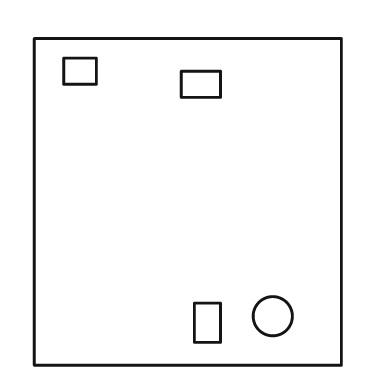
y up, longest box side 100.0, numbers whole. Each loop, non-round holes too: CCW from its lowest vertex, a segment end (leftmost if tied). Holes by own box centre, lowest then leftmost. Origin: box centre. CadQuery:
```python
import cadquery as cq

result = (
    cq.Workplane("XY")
    .moveTo(-47.0, -50.0)
    .lineTo(47.0, -50.0)
    .lineTo(47.0, 50.0)
    .lineTo(-47.0, 50.0)
    .close()
    .moveTo(2.0, -43.0)
    .lineTo(10.0, -43.0)
    .lineTo(10.0, -31.0)
    .lineTo(2.0, -31.0)
    .close()
    .moveTo(26.0, -35.0)
    .circle(6.0)
    .moveTo(-2.0, 32.0)
    .lineTo(10.0, 32.0)
    .lineTo(10.0, 40.0)
    .lineTo(-2.0, 40.0)
    .close()
    .moveTo(-38.0, 36.0)
    .lineTo(-28.0, 36.0)
    .lineTo(-28.0, 44.0)
    .lineTo(-38.0, 44.0)
    .close()
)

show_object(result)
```